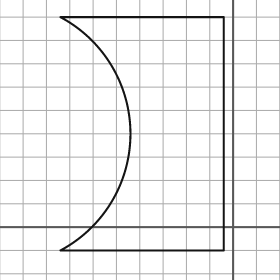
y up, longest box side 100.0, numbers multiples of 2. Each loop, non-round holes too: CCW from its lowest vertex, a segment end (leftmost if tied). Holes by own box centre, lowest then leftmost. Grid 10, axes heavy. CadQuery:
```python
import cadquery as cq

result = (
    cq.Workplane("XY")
    .moveTo(-74.0, -10.0)
    .lineTo(-4.0, -10.0)
    .lineTo(-4.0, 90.0)
    .lineTo(-74.0, 90.0)
    .threePointArc((-44.0, 40.0), (-74.0, -10.0))
    .close()
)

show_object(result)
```